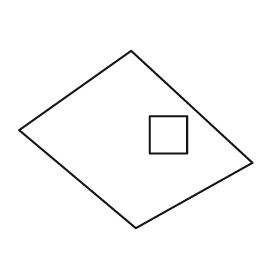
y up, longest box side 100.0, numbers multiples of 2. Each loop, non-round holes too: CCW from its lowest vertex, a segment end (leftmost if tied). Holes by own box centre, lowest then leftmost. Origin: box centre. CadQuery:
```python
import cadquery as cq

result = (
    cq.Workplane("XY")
    .moveTo(0.0, -38.0)
    .lineTo(50.0, -10.0)
    .lineTo(-2.0, 38.0)
    .lineTo(-50.0, 4.0)
    .close()
    .moveTo(6.0, -6.0)
    .lineTo(22.0, -6.0)
    .lineTo(22.0, 10.0)
    .lineTo(6.0, 10.0)
    .close()
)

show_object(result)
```